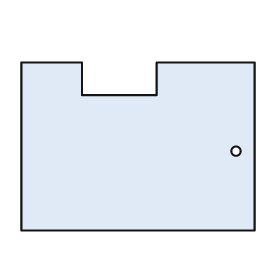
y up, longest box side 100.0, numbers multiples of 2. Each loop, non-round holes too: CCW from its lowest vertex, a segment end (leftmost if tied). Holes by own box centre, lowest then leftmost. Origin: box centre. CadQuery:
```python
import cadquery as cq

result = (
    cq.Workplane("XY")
    .moveTo(-50.0, -36.0)
    .lineTo(50.0, -36.0)
    .lineTo(50.0, 36.0)
    .lineTo(8.0, 36.0)
    .lineTo(8.0, 22.0)
    .lineTo(-24.0, 22.0)
    .lineTo(-24.0, 36.0)
    .lineTo(-50.0, 36.0)
    .close()
    .moveTo(42.0, -2.0)
    .circle(2.0)
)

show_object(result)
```